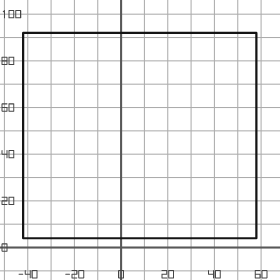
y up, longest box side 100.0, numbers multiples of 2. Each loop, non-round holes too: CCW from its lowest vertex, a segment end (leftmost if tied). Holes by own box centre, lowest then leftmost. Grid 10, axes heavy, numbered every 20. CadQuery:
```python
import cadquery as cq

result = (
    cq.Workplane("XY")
    .moveTo(-42.0, 4.0)
    .lineTo(58.0, 4.0)
    .lineTo(58.0, 92.0)
    .lineTo(-42.0, 92.0)
    .close()
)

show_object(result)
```